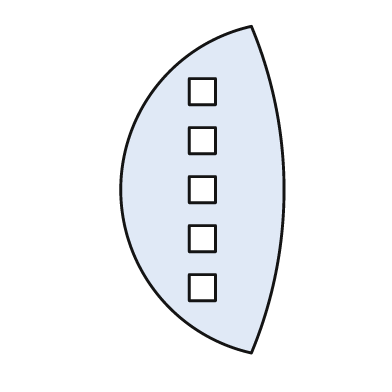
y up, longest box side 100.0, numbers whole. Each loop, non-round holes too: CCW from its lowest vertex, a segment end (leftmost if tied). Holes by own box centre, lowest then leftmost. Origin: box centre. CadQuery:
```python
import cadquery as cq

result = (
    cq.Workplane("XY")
    .moveTo(15.0, -50.0)
    .threePointArc((25.0, 0.0), (15.0, 50.0))
    .threePointArc((-25.0, 0.0), (15.0, -50.0))
    .close()
    .moveTo(-4.0, -34.0)
    .lineTo(4.0, -34.0)
    .lineTo(4.0, -26.0)
    .lineTo(-4.0, -26.0)
    .close()
    .moveTo(-4.0, -19.0)
    .lineTo(4.0, -19.0)
    .lineTo(4.0, -11.0)
    .lineTo(-4.0, -11.0)
    .close()
    .moveTo(-4.0, -4.0)
    .lineTo(4.0, -4.0)
    .lineTo(4.0, 4.0)
    .lineTo(-4.0, 4.0)
    .close()
    .moveTo(-4.0, 11.0)
    .lineTo(4.0, 11.0)
    .lineTo(4.0, 19.0)
    .lineTo(-4.0, 19.0)
    .close()
    .moveTo(-4.0, 26.0)
    .lineTo(4.0, 26.0)
    .lineTo(4.0, 34.0)
    .lineTo(-4.0, 34.0)
    .close()
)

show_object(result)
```